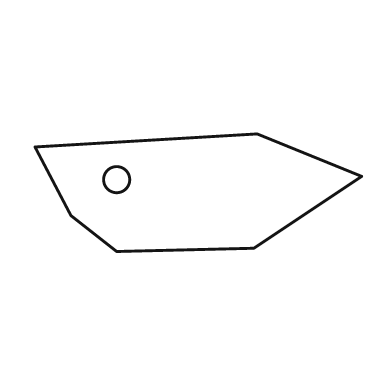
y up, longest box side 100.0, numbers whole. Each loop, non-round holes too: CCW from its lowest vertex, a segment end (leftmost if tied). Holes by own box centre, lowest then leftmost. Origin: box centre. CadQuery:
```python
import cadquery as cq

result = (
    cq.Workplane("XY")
    .moveTo(-25.0, -18.0)
    .lineTo(17.0, -17.0)
    .lineTo(50.0, 5.0)
    .lineTo(18.0, 18.0)
    .lineTo(-50.0, 14.0)
    .lineTo(-39.0, -7.0)
    .close()
    .moveTo(-25.0, 4.0)
    .circle(4.0)
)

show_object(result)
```